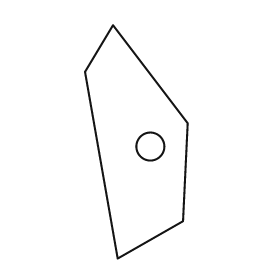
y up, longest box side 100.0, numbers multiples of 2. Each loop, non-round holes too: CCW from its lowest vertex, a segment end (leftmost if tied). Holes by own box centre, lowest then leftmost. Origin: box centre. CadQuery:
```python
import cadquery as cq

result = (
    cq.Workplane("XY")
    .moveTo(-8.0, -50.0)
    .lineTo(20.0, -34.0)
    .lineTo(22.0, 8.0)
    .lineTo(-10.0, 50.0)
    .lineTo(-22.0, 30.0)
    .close()
    .moveTo(6.0, -2.0)
    .circle(6.0)
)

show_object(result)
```